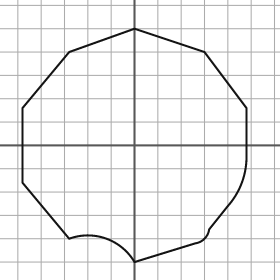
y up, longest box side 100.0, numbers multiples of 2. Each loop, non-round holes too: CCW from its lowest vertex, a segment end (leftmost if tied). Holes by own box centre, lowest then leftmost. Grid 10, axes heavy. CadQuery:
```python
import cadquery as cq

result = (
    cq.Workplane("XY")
    .moveTo(0.0, -50.0)
    .lineTo(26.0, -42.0)
    .threePointArc((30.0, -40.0), (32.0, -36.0))
    .lineTo(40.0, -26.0)
    .threePointArc((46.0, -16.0), (48.0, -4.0))
    .lineTo(48.0, 16.0)
    .lineTo(30.0, 40.0)
    .lineTo(0.0, 50.0)
    .lineTo(-28.0, 40.0)
    .lineTo(-48.0, 16.0)
    .lineTo(-48.0, -16.0)
    .lineTo(-28.0, -40.0)
    .threePointArc((-12.0, -40.0), (0.0, -50.0))
    .close()
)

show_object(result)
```